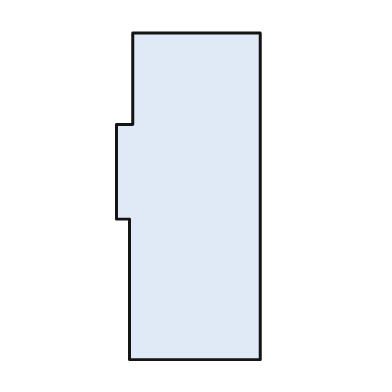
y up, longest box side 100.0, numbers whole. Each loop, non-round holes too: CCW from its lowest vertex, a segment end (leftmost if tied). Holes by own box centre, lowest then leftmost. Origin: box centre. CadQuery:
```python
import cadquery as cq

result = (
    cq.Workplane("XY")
    .moveTo(-18.0, -50.0)
    .lineTo(22.0, -50.0)
    .lineTo(22.0, 50.0)
    .lineTo(-17.0, 50.0)
    .lineTo(-17.0, 22.0)
    .lineTo(-22.0, 22.0)
    .lineTo(-22.0, -7.0)
    .lineTo(-18.0, -7.0)
    .close()
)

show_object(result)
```